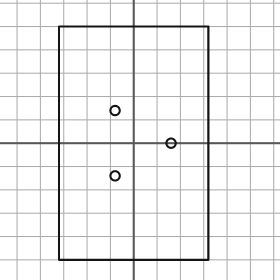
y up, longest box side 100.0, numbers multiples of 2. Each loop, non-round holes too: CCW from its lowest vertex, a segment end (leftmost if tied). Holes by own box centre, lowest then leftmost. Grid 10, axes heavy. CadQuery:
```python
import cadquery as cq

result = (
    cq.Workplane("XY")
    .moveTo(-32.0, -50.0)
    .lineTo(32.0, -50.0)
    .lineTo(32.0, 50.0)
    .lineTo(-32.0, 50.0)
    .close()
    .moveTo(-8.0, -14.0)
    .circle(2.0)
    .moveTo(16.0, 0.0)
    .circle(2.0)
    .moveTo(-8.0, 14.0)
    .circle(2.0)
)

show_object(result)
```